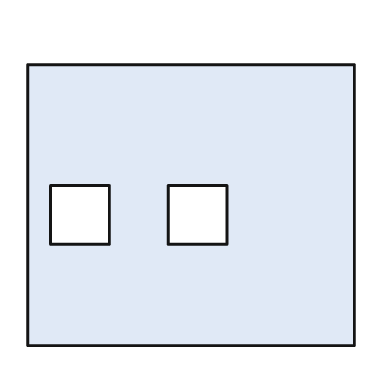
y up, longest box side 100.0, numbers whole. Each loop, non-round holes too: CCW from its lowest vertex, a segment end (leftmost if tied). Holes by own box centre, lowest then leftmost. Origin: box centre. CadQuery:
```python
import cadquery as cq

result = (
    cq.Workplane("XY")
    .moveTo(-50.0, -43.0)
    .lineTo(50.0, -43.0)
    .lineTo(50.0, 43.0)
    .lineTo(-50.0, 43.0)
    .close()
    .moveTo(-43.0, -12.0)
    .lineTo(-25.0, -12.0)
    .lineTo(-25.0, 6.0)
    .lineTo(-43.0, 6.0)
    .close()
    .moveTo(-7.0, -12.0)
    .lineTo(11.0, -12.0)
    .lineTo(11.0, 6.0)
    .lineTo(-7.0, 6.0)
    .close()
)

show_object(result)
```